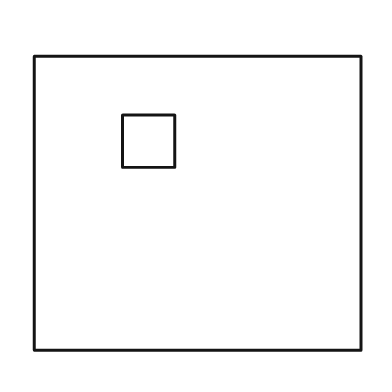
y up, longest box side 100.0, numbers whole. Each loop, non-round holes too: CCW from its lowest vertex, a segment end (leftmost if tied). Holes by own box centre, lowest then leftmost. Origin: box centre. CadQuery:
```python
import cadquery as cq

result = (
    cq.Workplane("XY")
    .moveTo(-50.0, -45.0)
    .lineTo(50.0, -45.0)
    .lineTo(50.0, 45.0)
    .lineTo(-50.0, 45.0)
    .close()
    .moveTo(-23.0, 11.0)
    .lineTo(-7.0, 11.0)
    .lineTo(-7.0, 27.0)
    .lineTo(-23.0, 27.0)
    .close()
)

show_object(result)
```